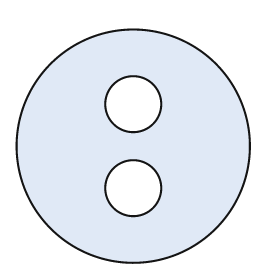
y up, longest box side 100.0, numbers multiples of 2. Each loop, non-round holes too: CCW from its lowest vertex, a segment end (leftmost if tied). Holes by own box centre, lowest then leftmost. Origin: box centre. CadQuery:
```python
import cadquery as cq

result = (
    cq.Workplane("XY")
    .moveTo(0.0, 0.0)
    .circle(50.0)
    .moveTo(0.0, -18.0)
    .circle(12.0)
    .moveTo(0.0, 18.0)
    .circle(12.0)
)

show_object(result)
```